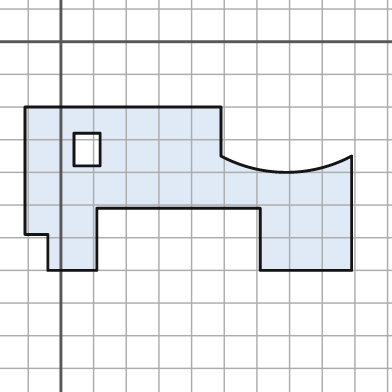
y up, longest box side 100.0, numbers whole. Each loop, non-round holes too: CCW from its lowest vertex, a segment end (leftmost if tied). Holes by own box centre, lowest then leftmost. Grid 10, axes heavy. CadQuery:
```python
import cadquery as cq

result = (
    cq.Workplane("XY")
    .moveTo(-4.0, -70.0)
    .lineTo(11.0, -70.0)
    .lineTo(11.0, -51.0)
    .lineTo(61.0, -51.0)
    .lineTo(61.0, -70.0)
    .lineTo(89.0, -70.0)
    .lineTo(89.0, -35.0)
    .threePointArc((69.0, -40.0), (49.0, -35.0))
    .lineTo(49.0, -20.0)
    .lineTo(-11.0, -20.0)
    .lineTo(-11.0, -59.0)
    .lineTo(-4.0, -59.0)
    .close()
    .moveTo(4.0, -38.0)
    .lineTo(12.0, -38.0)
    .lineTo(12.0, -28.0)
    .lineTo(4.0, -28.0)
    .close()
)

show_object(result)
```